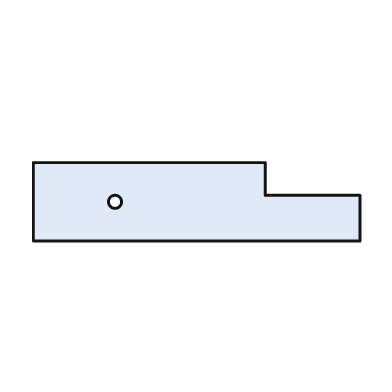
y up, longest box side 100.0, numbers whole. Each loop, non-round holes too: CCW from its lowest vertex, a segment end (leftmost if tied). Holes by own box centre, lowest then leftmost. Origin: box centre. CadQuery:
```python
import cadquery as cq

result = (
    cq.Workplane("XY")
    .moveTo(-50.0, -12.0)
    .lineTo(50.0, -12.0)
    .lineTo(50.0, 2.0)
    .lineTo(21.0, 2.0)
    .lineTo(21.0, 12.0)
    .lineTo(-50.0, 12.0)
    .close()
    .moveTo(-25.0, 0.0)
    .circle(2.0)
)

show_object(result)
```